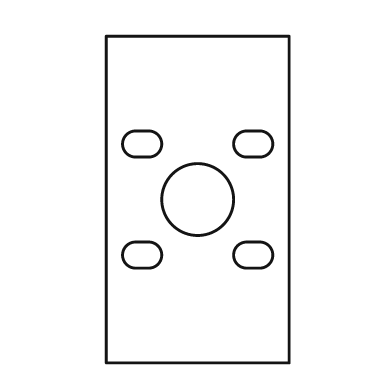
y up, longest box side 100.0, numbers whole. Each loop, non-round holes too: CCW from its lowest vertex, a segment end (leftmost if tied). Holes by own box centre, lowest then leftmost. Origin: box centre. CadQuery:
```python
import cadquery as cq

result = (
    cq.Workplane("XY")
    .moveTo(-28.0, -50.0)
    .lineTo(28.0, -50.0)
    .lineTo(28.0, 50.0)
    .lineTo(-28.0, 50.0)
    .close()
    .moveTo(-19.0, -21.0)
    .lineTo(-15.0, -21.0)
    .threePointArc((-11.0, -17.0), (-15.0, -13.0))
    .lineTo(-19.0, -13.0)
    .threePointArc((-23.0, -17.0), (-19.0, -21.0))
    .close()
    .moveTo(15.0, -21.0)
    .lineTo(19.0, -21.0)
    .threePointArc((23.0, -17.0), (19.0, -13.0))
    .lineTo(15.0, -13.0)
    .threePointArc((11.0, -17.0), (15.0, -21.0))
    .close()
    .moveTo(0.0, 0.0)
    .circle(11.0)
    .moveTo(-19.0, 13.0)
    .lineTo(-15.0, 13.0)
    .threePointArc((-11.0, 17.0), (-15.0, 21.0))
    .lineTo(-19.0, 21.0)
    .threePointArc((-23.0, 17.0), (-19.0, 13.0))
    .close()
    .moveTo(15.0, 13.0)
    .lineTo(19.0, 13.0)
    .threePointArc((23.0, 17.0), (19.0, 21.0))
    .lineTo(15.0, 21.0)
    .threePointArc((11.0, 17.0), (15.0, 13.0))
    .close()
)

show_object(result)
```